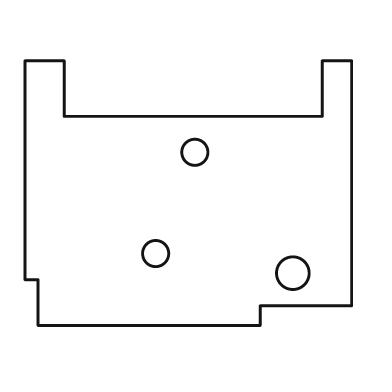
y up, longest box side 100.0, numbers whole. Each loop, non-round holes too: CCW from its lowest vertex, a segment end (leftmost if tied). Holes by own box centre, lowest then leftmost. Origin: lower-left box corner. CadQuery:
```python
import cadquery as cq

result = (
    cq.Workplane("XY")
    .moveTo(4.0, 0.0)
    .lineTo(72.0, 0.0)
    .lineTo(72.0, 6.0)
    .lineTo(100.0, 6.0)
    .lineTo(100.0, 81.0)
    .lineTo(91.0, 81.0)
    .lineTo(91.0, 64.0)
    .lineTo(12.0, 64.0)
    .lineTo(12.0, 81.0)
    .lineTo(0.0, 81.0)
    .lineTo(0.0, 14.0)
    .lineTo(4.0, 14.0)
    .close()
    .moveTo(82.0, 16.0)
    .circle(5.0)
    .moveTo(40.0, 22.0)
    .circle(4.0)
    .moveTo(52.0, 53.0)
    .circle(4.0)
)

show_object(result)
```